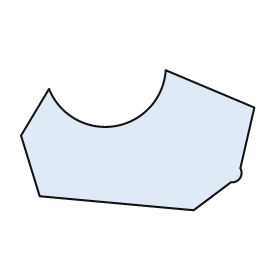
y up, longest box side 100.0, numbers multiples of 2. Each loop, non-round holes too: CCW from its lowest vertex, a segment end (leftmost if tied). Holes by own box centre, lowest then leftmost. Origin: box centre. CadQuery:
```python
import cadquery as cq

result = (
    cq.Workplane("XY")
    .moveTo(24.0, -30.0)
    .lineTo(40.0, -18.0)
    .threePointArc((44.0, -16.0), (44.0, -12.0))
    .lineTo(50.0, 14.0)
    .lineTo(12.0, 30.0)
    .threePointArc((-10.0, 6.0), (-38.0, 22.0))
    .lineTo(-50.0, 2.0)
    .lineTo(-42.0, -24.0)
    .close()
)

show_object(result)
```